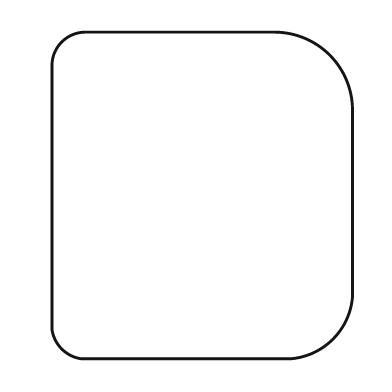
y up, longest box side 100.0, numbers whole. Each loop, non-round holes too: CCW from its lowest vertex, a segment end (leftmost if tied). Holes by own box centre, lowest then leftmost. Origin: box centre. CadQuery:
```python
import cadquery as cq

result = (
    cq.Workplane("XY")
    .moveTo(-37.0, -50.0)
    .lineTo(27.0, -50.0)
    .threePointArc((40.0, -44.0), (46.0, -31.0))
    .lineTo(46.0, 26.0)
    .threePointArc((39.0, 43.0), (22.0, 50.0))
    .lineTo(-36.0, 50.0)
    .threePointArc((-43.0, 47.0), (-46.0, 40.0))
    .lineTo(-46.0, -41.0)
    .threePointArc((-43.0, -47.0), (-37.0, -50.0))
    .close()
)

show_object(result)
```